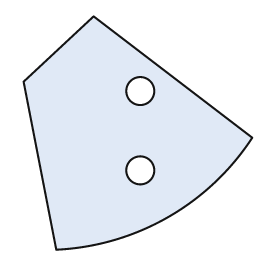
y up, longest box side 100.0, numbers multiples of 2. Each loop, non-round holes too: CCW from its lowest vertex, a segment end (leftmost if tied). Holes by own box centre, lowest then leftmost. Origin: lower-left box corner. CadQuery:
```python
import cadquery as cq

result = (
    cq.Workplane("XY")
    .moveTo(14.0, 0.0)
    .threePointArc((62.0, 14.0), (98.0, 48.0))
    .lineTo(30.0, 100.0)
    .lineTo(0.0, 72.0)
    .close()
    .moveTo(50.0, 34.0)
    .circle(6.0)
    .moveTo(50.0, 68.0)
    .circle(6.0)
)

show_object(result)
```